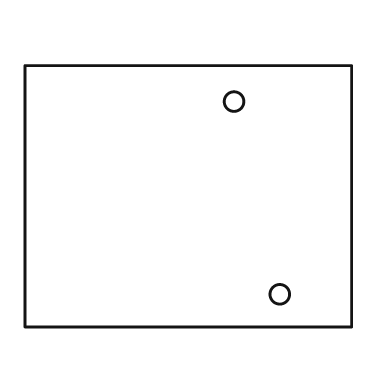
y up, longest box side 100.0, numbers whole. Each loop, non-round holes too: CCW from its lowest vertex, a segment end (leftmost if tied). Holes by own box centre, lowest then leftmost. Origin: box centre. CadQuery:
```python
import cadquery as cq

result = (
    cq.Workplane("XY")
    .moveTo(-50.0, -40.0)
    .lineTo(50.0, -40.0)
    .lineTo(50.0, 40.0)
    .lineTo(-50.0, 40.0)
    .close()
    .moveTo(28.0, -30.0)
    .circle(3.0)
    .moveTo(14.0, 29.0)
    .circle(3.0)
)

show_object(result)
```